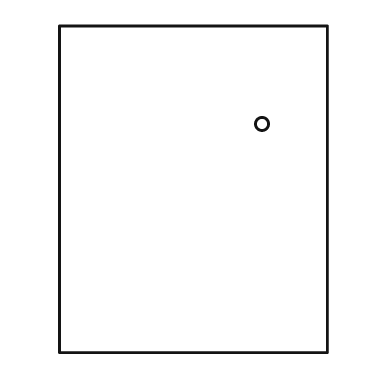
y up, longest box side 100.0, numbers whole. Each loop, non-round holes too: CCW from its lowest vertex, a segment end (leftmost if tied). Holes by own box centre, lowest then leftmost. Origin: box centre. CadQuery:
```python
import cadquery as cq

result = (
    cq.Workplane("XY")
    .moveTo(-41.0, -50.0)
    .lineTo(41.0, -50.0)
    .lineTo(41.0, 50.0)
    .lineTo(-41.0, 50.0)
    .close()
    .moveTo(21.0, 20.0)
    .circle(2.0)
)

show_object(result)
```